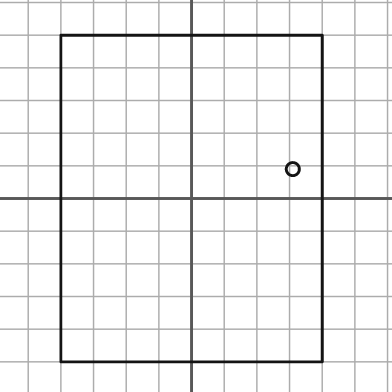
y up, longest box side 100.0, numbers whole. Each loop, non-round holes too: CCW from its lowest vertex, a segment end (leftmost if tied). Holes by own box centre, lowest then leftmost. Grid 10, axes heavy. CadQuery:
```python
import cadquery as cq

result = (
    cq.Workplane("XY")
    .moveTo(-40.0, -50.0)
    .lineTo(40.0, -50.0)
    .lineTo(40.0, 50.0)
    .lineTo(-40.0, 50.0)
    .close()
    .moveTo(31.0, 9.0)
    .circle(2.0)
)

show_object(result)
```